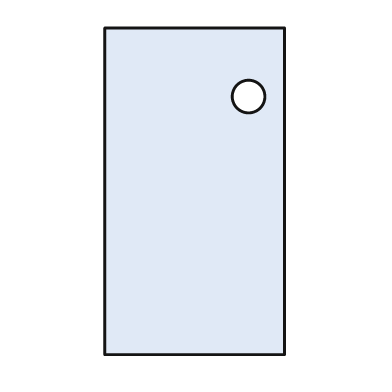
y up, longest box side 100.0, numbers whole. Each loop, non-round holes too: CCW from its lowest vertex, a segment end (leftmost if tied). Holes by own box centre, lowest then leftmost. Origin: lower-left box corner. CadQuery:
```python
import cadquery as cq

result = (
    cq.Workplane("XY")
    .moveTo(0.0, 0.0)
    .lineTo(55.0, 0.0)
    .lineTo(55.0, 100.0)
    .lineTo(0.0, 100.0)
    .close()
    .moveTo(44.0, 79.0)
    .circle(5.0)
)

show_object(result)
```